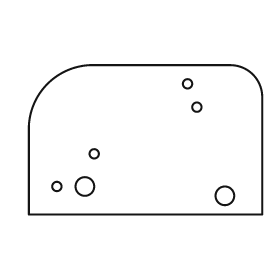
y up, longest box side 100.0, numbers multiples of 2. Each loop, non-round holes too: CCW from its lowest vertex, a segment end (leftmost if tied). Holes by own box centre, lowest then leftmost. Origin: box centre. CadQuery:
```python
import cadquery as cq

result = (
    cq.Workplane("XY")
    .moveTo(-50.0, -32.0)
    .lineTo(50.0, -32.0)
    .lineTo(50.0, 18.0)
    .threePointArc((46.0, 28.0), (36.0, 32.0))
    .lineTo(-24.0, 32.0)
    .threePointArc((-42.0, 24.0), (-50.0, 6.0))
    .close()
    .moveTo(34.0, -24.0)
    .circle(4.0)
    .moveTo(-38.0, -20.0)
    .circle(2.0)
    .moveTo(-26.0, -20.0)
    .circle(4.0)
    .moveTo(-22.0, -6.0)
    .circle(2.0)
    .moveTo(22.0, 14.0)
    .circle(2.0)
    .moveTo(18.0, 24.0)
    .circle(2.0)
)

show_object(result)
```